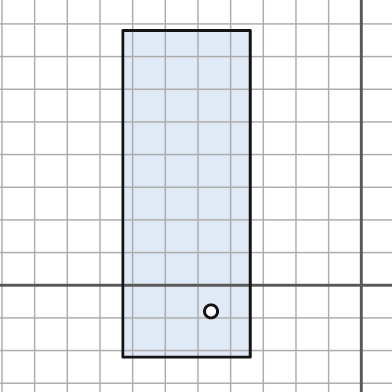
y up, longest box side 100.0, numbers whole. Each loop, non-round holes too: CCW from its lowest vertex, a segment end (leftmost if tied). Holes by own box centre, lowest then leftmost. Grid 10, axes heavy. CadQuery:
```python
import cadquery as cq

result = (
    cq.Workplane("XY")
    .moveTo(-73.0, -22.0)
    .lineTo(-34.0, -22.0)
    .lineTo(-34.0, 78.0)
    .lineTo(-73.0, 78.0)
    .close()
    .moveTo(-46.0, -8.0)
    .circle(2.0)
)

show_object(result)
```